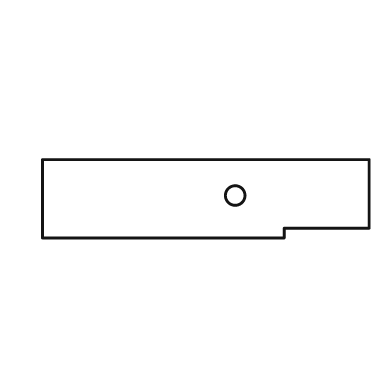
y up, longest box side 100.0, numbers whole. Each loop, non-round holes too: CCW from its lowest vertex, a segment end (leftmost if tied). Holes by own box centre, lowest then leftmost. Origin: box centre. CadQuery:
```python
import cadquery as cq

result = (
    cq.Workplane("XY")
    .moveTo(-50.0, -12.0)
    .lineTo(24.0, -12.0)
    .lineTo(24.0, -9.0)
    .lineTo(50.0, -9.0)
    .lineTo(50.0, 12.0)
    .lineTo(-50.0, 12.0)
    .close()
    .moveTo(9.0, 1.0)
    .circle(3.0)
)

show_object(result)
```